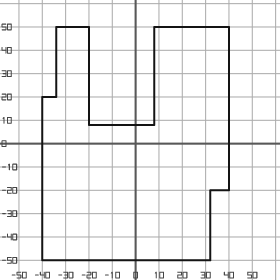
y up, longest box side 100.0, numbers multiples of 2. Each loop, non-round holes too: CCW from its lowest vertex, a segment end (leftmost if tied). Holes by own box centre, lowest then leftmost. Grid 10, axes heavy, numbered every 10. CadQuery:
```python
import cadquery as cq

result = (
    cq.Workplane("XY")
    .moveTo(-40.0, -50.0)
    .lineTo(32.0, -50.0)
    .lineTo(32.0, -20.0)
    .lineTo(40.0, -20.0)
    .lineTo(40.0, 50.0)
    .lineTo(8.0, 50.0)
    .lineTo(8.0, 8.0)
    .lineTo(-20.0, 8.0)
    .lineTo(-20.0, 50.0)
    .lineTo(-34.0, 50.0)
    .lineTo(-34.0, 20.0)
    .lineTo(-40.0, 20.0)
    .close()
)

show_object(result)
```